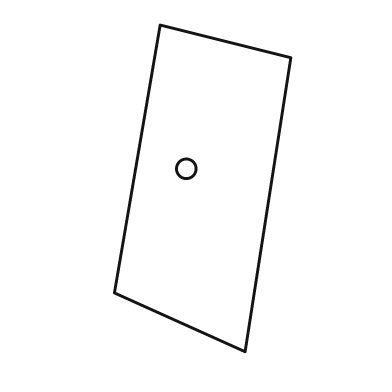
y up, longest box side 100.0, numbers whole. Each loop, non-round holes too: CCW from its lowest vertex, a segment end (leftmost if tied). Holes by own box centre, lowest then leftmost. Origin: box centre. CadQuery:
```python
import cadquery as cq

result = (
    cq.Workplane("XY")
    .moveTo(13.0, -50.0)
    .lineTo(27.0, 40.0)
    .lineTo(-13.0, 50.0)
    .lineTo(-27.0, -32.0)
    .close()
    .moveTo(-5.0, 6.0)
    .circle(3.0)
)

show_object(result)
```